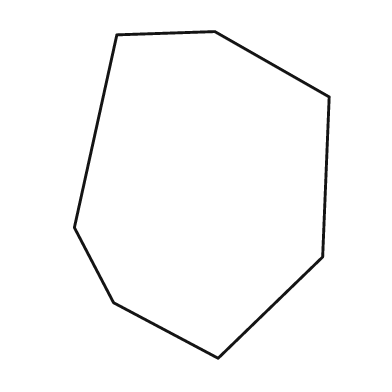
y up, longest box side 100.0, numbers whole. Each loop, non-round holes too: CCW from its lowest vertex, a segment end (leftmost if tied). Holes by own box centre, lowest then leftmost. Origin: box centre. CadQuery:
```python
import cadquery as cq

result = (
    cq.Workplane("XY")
    .moveTo(5.0, -50.0)
    .lineTo(37.0, -19.0)
    .lineTo(39.0, 30.0)
    .lineTo(4.0, 50.0)
    .lineTo(-26.0, 49.0)
    .lineTo(-39.0, -10.0)
    .lineTo(-27.0, -33.0)
    .close()
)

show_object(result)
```